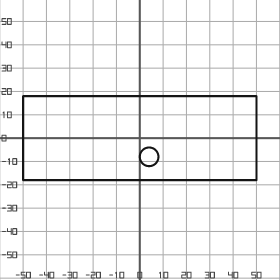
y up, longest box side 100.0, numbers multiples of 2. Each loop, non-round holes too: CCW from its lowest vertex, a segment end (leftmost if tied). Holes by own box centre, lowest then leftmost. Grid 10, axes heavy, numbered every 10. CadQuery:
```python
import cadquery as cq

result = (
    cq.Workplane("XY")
    .moveTo(-50.0, -18.0)
    .lineTo(50.0, -18.0)
    .lineTo(50.0, 18.0)
    .lineTo(-50.0, 18.0)
    .close()
    .moveTo(4.0, -8.0)
    .circle(4.0)
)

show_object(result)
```